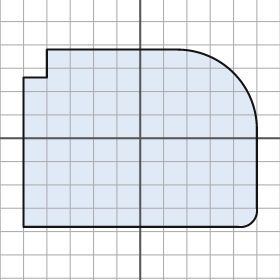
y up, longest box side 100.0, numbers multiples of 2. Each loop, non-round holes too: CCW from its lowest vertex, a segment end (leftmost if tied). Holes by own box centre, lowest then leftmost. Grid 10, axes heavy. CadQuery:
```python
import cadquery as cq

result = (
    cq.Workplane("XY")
    .moveTo(-50.0, -38.0)
    .lineTo(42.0, -38.0)
    .threePointArc((48.0, -36.0), (50.0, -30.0))
    .lineTo(50.0, 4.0)
    .threePointArc((40.0, 28.0), (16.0, 38.0))
    .lineTo(-40.0, 38.0)
    .lineTo(-40.0, 26.0)
    .lineTo(-50.0, 26.0)
    .close()
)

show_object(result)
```